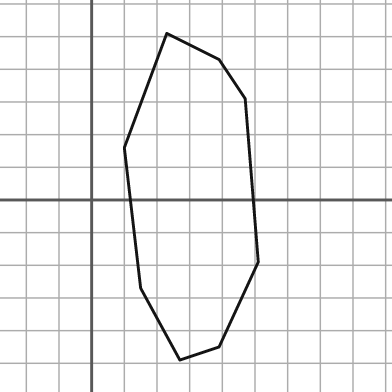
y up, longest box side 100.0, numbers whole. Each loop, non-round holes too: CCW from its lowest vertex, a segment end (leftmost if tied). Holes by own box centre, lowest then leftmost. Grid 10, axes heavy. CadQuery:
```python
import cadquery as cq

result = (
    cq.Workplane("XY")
    .moveTo(27.0, -49.0)
    .lineTo(39.0, -45.0)
    .lineTo(51.0, -19.0)
    .lineTo(47.0, 31.0)
    .lineTo(39.0, 43.0)
    .lineTo(23.0, 51.0)
    .lineTo(10.0, 16.0)
    .lineTo(15.0, -27.0)
    .close()
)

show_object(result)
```